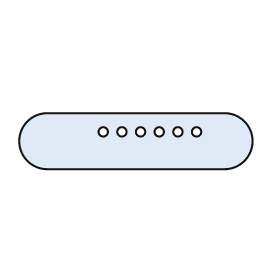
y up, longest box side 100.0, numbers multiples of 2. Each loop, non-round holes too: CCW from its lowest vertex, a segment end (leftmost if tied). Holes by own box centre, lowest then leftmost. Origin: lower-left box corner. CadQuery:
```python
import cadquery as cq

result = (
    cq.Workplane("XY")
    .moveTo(12.0, 0.0)
    .lineTo(88.0, 0.0)
    .threePointArc((100.0, 12.0), (88.0, 24.0))
    .lineTo(12.0, 24.0)
    .threePointArc((0.0, 12.0), (12.0, 0.0))
    .close()
    .moveTo(36.0, 16.0)
    .circle(2.0)
    .moveTo(44.0, 16.0)
    .circle(2.0)
    .moveTo(52.0, 16.0)
    .circle(2.0)
    .moveTo(60.0, 16.0)
    .circle(2.0)
    .moveTo(68.0, 16.0)
    .circle(2.0)
    .moveTo(76.0, 16.0)
    .circle(2.0)
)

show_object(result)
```